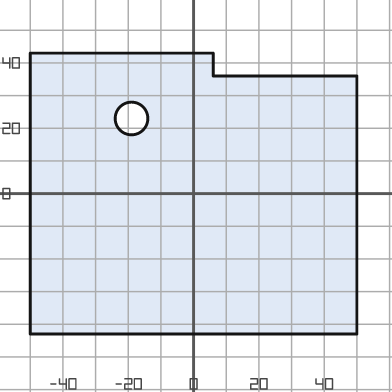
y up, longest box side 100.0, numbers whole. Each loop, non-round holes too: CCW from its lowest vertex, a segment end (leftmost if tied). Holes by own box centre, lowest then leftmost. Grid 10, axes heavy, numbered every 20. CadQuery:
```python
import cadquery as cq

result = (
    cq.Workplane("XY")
    .moveTo(-50.0, -43.0)
    .lineTo(50.0, -43.0)
    .lineTo(50.0, 36.0)
    .lineTo(6.0, 36.0)
    .lineTo(6.0, 43.0)
    .lineTo(-50.0, 43.0)
    .close()
    .moveTo(-19.0, 23.0)
    .circle(5.0)
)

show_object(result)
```